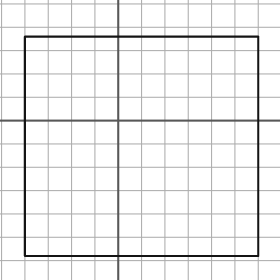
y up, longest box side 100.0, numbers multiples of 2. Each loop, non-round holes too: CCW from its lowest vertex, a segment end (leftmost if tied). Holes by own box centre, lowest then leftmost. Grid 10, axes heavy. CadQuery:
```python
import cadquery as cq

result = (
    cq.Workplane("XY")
    .moveTo(-40.0, -58.0)
    .lineTo(60.0, -58.0)
    .lineTo(60.0, 36.0)
    .lineTo(-40.0, 36.0)
    .close()
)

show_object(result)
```